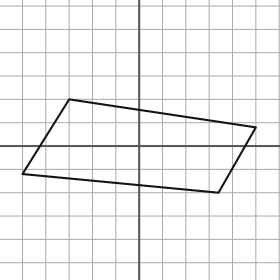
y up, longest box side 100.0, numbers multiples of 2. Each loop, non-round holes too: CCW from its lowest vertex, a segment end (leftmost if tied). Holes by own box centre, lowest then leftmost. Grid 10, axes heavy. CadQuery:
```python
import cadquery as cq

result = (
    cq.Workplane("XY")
    .moveTo(34.0, -20.0)
    .lineTo(50.0, 8.0)
    .lineTo(-30.0, 20.0)
    .lineTo(-50.0, -12.0)
    .close()
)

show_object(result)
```